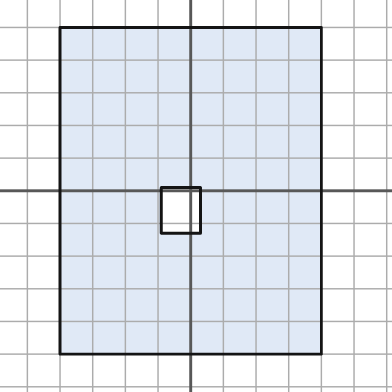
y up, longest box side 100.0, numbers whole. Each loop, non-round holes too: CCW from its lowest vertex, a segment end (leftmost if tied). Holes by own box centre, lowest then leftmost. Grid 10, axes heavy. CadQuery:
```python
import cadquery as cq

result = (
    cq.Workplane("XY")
    .moveTo(-40.0, -50.0)
    .lineTo(40.0, -50.0)
    .lineTo(40.0, 50.0)
    .lineTo(-40.0, 50.0)
    .close()
    .moveTo(-9.0, -13.0)
    .lineTo(3.0, -13.0)
    .lineTo(3.0, 1.0)
    .lineTo(-9.0, 1.0)
    .close()
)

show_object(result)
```